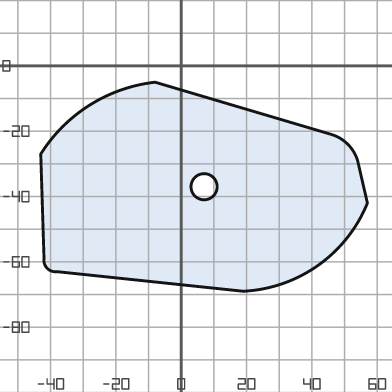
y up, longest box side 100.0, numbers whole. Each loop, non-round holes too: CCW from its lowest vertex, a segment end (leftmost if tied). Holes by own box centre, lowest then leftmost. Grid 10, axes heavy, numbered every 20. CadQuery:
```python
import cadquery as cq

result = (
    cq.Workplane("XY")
    .moveTo(19.0, -69.0)
    .threePointArc((42.0, -61.0), (57.0, -42.0))
    .lineTo(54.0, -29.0)
    .threePointArc((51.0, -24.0), (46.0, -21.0))
    .lineTo(-8.0, -5.0)
    .threePointArc((-28.0, -12.0), (-43.0, -27.0))
    .lineTo(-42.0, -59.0)
    .threePointArc((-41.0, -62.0), (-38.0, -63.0))
    .close()
    .moveTo(7.0, -37.0)
    .circle(4.0)
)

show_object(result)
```